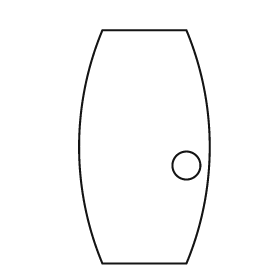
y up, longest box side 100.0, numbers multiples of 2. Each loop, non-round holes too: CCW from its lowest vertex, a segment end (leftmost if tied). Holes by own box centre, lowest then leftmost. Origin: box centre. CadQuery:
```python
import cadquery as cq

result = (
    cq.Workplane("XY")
    .moveTo(-18.0, -50.0)
    .lineTo(18.0, -50.0)
    .threePointArc((28.0, 0.0), (18.0, 50.0))
    .lineTo(-18.0, 50.0)
    .threePointArc((-28.0, 0.0), (-18.0, -50.0))
    .close()
    .moveTo(18.0, -8.0)
    .circle(6.0)
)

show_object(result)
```